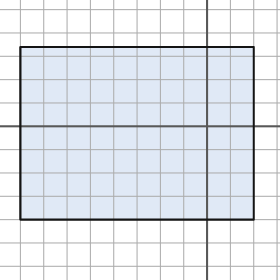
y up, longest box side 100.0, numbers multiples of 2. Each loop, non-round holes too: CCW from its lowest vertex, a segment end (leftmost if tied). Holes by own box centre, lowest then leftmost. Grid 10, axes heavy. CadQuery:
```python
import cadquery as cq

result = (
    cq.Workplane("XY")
    .moveTo(-80.0, -40.0)
    .lineTo(20.0, -40.0)
    .lineTo(20.0, 34.0)
    .lineTo(-80.0, 34.0)
    .close()
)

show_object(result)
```